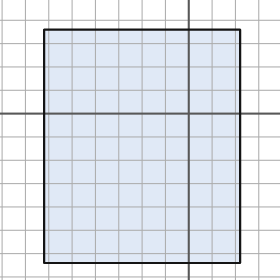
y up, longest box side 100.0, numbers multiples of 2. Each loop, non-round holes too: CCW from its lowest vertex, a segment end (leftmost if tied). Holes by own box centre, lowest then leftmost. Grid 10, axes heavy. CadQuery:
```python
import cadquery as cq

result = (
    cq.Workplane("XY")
    .moveTo(-62.0, -64.0)
    .lineTo(22.0, -64.0)
    .lineTo(22.0, 36.0)
    .lineTo(-62.0, 36.0)
    .close()
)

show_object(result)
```